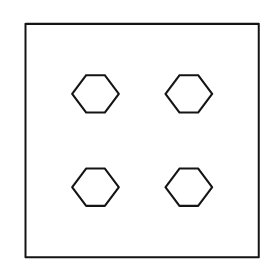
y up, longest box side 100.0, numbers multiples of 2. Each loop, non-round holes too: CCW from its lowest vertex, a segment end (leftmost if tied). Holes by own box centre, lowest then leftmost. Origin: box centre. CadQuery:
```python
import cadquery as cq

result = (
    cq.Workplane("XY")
    .moveTo(-50.0, -50.0)
    .lineTo(50.0, -50.0)
    .lineTo(50.0, 50.0)
    .lineTo(-50.0, 50.0)
    .close()
    .moveTo(-24.0, -28.0)
    .lineTo(-16.0, -28.0)
    .lineTo(-10.0, -20.0)
    .lineTo(-16.0, -12.0)
    .lineTo(-24.0, -12.0)
    .lineTo(-30.0, -20.0)
    .close()
    .moveTo(16.0, -28.0)
    .lineTo(24.0, -28.0)
    .lineTo(30.0, -20.0)
    .lineTo(24.0, -12.0)
    .lineTo(16.0, -12.0)
    .lineTo(10.0, -20.0)
    .close()
    .moveTo(-24.0, 12.0)
    .lineTo(-16.0, 12.0)
    .lineTo(-10.0, 20.0)
    .lineTo(-16.0, 28.0)
    .lineTo(-24.0, 28.0)
    .lineTo(-30.0, 20.0)
    .close()
    .moveTo(16.0, 12.0)
    .lineTo(24.0, 12.0)
    .lineTo(30.0, 20.0)
    .lineTo(24.0, 28.0)
    .lineTo(16.0, 28.0)
    .lineTo(10.0, 20.0)
    .close()
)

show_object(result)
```